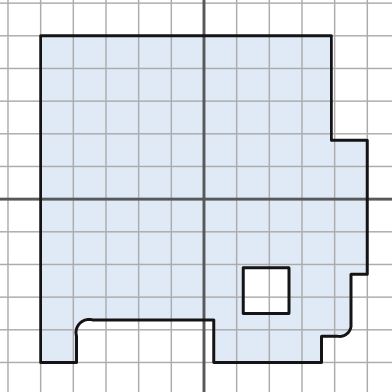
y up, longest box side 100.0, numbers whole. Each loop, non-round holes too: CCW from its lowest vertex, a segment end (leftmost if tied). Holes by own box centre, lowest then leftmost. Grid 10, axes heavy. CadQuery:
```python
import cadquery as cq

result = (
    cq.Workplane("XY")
    .moveTo(-50.0, -50.0)
    .lineTo(-39.0, -50.0)
    .lineTo(-39.0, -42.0)
    .threePointArc((-38.0, -38.0), (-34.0, -37.0))
    .lineTo(3.0, -37.0)
    .lineTo(3.0, -50.0)
    .lineTo(36.0, -50.0)
    .lineTo(36.0, -42.0)
    .lineTo(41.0, -42.0)
    .threePointArc((44.0, -41.0), (45.0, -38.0))
    .lineTo(45.0, -23.0)
    .lineTo(50.0, -23.0)
    .lineTo(50.0, 18.0)
    .lineTo(39.0, 18.0)
    .lineTo(39.0, 50.0)
    .lineTo(-50.0, 50.0)
    .close()
    .moveTo(12.0, -35.0)
    .lineTo(26.0, -35.0)
    .lineTo(26.0, -21.0)
    .lineTo(12.0, -21.0)
    .close()
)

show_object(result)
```